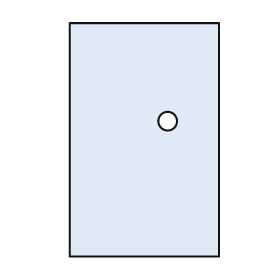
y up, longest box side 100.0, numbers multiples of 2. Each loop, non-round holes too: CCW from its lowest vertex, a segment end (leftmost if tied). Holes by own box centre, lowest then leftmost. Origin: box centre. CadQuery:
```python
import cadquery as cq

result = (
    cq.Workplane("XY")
    .moveTo(-32.0, -50.0)
    .lineTo(32.0, -50.0)
    .lineTo(32.0, 50.0)
    .lineTo(-32.0, 50.0)
    .close()
    .moveTo(10.0, 8.0)
    .circle(4.0)
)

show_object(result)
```